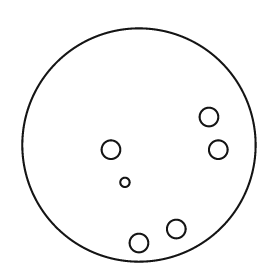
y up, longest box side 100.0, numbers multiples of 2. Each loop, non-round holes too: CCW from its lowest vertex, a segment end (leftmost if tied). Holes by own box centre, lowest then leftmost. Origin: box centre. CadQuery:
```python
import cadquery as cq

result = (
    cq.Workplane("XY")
    .moveTo(0.0, 0.0)
    .circle(50.0)
    .moveTo(0.0, -42.0)
    .circle(4.0)
    .moveTo(16.0, -36.0)
    .circle(4.0)
    .moveTo(-6.0, -16.0)
    .circle(2.0)
    .moveTo(-12.0, -2.0)
    .circle(4.0)
    .moveTo(34.0, -2.0)
    .circle(4.0)
    .moveTo(30.0, 12.0)
    .circle(4.0)
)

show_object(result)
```